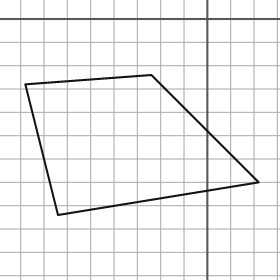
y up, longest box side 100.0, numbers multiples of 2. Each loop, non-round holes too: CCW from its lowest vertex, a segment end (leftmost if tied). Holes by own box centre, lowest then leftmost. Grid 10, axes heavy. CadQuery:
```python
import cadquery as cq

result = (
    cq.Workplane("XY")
    .moveTo(-64.0, -84.0)
    .lineTo(22.0, -70.0)
    .lineTo(-24.0, -24.0)
    .lineTo(-78.0, -28.0)
    .close()
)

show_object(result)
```